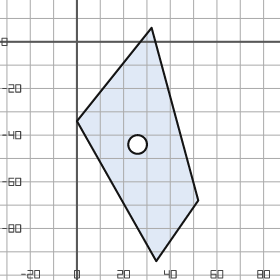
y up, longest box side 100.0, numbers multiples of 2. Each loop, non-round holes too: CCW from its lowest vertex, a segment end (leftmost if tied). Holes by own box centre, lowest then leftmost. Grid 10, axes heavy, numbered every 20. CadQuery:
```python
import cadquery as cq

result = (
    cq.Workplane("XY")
    .moveTo(34.0, -94.0)
    .lineTo(52.0, -68.0)
    .lineTo(32.0, 6.0)
    .lineTo(0.0, -34.0)
    .close()
    .moveTo(26.0, -44.0)
    .circle(4.0)
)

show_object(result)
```